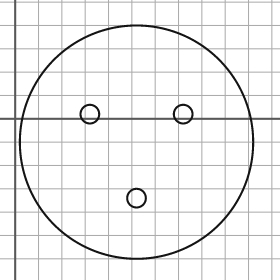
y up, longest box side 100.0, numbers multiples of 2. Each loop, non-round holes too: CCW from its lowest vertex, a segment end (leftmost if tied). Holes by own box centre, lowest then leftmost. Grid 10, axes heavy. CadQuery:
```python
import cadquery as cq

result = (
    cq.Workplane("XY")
    .moveTo(52.0, -10.0)
    .circle(50.0)
    .moveTo(52.0, -34.0)
    .circle(4.0)
    .moveTo(32.0, 2.0)
    .circle(4.0)
    .moveTo(72.0, 2.0)
    .circle(4.0)
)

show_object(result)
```